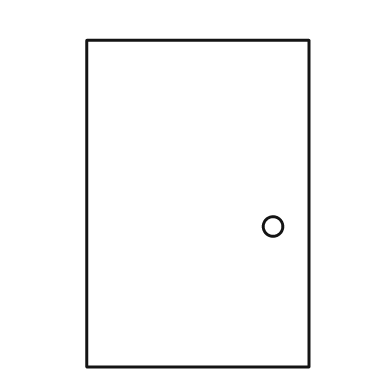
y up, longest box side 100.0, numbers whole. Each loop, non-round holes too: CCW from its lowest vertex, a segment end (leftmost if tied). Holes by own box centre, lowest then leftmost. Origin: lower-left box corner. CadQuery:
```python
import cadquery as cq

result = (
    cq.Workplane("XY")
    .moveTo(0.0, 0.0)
    .lineTo(68.0, 0.0)
    .lineTo(68.0, 100.0)
    .lineTo(0.0, 100.0)
    .close()
    .moveTo(57.0, 43.0)
    .circle(3.0)
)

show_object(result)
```